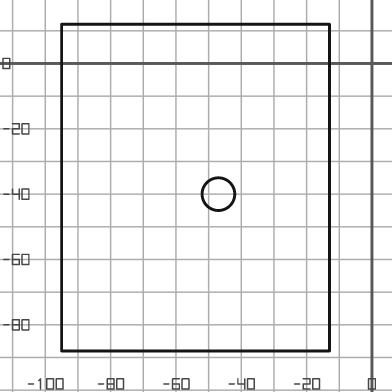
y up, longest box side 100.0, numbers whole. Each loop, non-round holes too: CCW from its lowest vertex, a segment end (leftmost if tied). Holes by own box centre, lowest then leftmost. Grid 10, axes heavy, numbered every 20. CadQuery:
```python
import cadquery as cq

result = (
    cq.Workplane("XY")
    .moveTo(-95.0, -88.0)
    .lineTo(-13.0, -88.0)
    .lineTo(-13.0, 12.0)
    .lineTo(-95.0, 12.0)
    .close()
    .moveTo(-47.0, -40.0)
    .circle(5.0)
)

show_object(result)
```